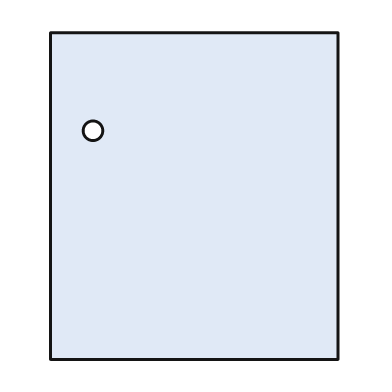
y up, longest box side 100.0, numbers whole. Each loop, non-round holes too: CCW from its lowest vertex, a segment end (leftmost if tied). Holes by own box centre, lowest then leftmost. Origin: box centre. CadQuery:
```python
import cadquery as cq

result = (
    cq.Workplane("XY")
    .moveTo(-44.0, -50.0)
    .lineTo(44.0, -50.0)
    .lineTo(44.0, 50.0)
    .lineTo(-44.0, 50.0)
    .close()
    .moveTo(-31.0, 20.0)
    .circle(3.0)
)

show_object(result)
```